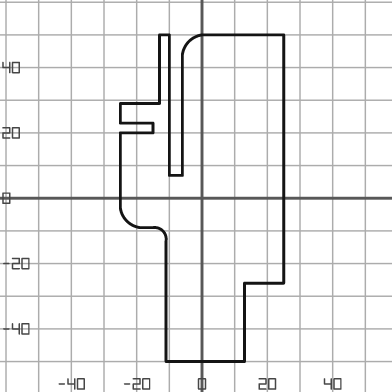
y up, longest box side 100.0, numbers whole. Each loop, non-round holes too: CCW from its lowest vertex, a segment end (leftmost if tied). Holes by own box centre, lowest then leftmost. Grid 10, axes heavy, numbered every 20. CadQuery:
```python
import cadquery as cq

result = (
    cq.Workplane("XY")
    .moveTo(-11.0, -50.0)
    .lineTo(13.0, -50.0)
    .lineTo(13.0, -26.0)
    .lineTo(25.0, -26.0)
    .lineTo(25.0, 50.0)
    .lineTo(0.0, 50.0)
    .threePointArc((-4.0, 48.0), (-6.0, 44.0))
    .lineTo(-6.0, 7.0)
    .lineTo(-10.0, 7.0)
    .lineTo(-10.0, 50.0)
    .lineTo(-13.0, 50.0)
    .lineTo(-13.0, 29.0)
    .lineTo(-25.0, 29.0)
    .lineTo(-25.0, 23.0)
    .lineTo(-15.0, 23.0)
    .lineTo(-15.0, 20.0)
    .lineTo(-25.0, 20.0)
    .lineTo(-25.0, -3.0)
    .threePointArc((-23.0, -7.0), (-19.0, -9.0))
    .lineTo(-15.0, -9.0)
    .threePointArc((-12.0, -10.0), (-11.0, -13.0))
    .close()
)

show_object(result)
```